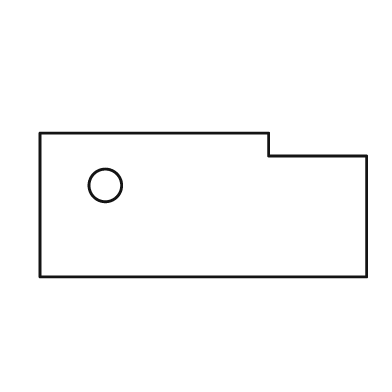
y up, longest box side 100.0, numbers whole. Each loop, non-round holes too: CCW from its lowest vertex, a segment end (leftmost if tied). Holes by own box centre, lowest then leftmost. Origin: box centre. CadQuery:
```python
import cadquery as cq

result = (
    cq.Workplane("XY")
    .moveTo(-50.0, -22.0)
    .lineTo(50.0, -22.0)
    .lineTo(50.0, 15.0)
    .lineTo(20.0, 15.0)
    .lineTo(20.0, 22.0)
    .lineTo(-50.0, 22.0)
    .close()
    .moveTo(-30.0, 6.0)
    .circle(5.0)
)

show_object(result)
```